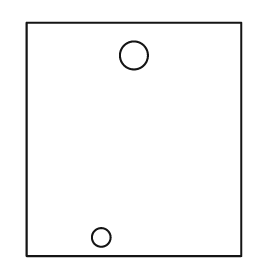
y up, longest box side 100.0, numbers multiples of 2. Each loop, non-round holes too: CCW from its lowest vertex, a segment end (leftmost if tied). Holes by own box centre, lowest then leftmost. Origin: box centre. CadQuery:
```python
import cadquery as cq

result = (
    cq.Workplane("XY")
    .moveTo(-46.0, -50.0)
    .lineTo(46.0, -50.0)
    .lineTo(46.0, 50.0)
    .lineTo(-46.0, 50.0)
    .close()
    .moveTo(-14.0, -42.0)
    .circle(4.0)
    .moveTo(0.0, 36.0)
    .circle(6.0)
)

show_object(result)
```